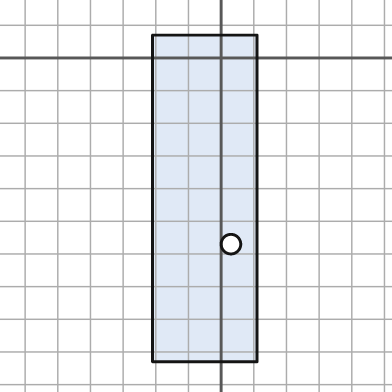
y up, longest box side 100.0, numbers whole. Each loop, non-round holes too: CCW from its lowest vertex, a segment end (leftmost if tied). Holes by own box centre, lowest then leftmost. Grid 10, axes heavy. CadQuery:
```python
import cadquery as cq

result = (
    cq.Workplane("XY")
    .moveTo(-21.0, -93.0)
    .lineTo(11.0, -93.0)
    .lineTo(11.0, 7.0)
    .lineTo(-21.0, 7.0)
    .close()
    .moveTo(3.0, -57.0)
    .circle(3.0)
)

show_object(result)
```